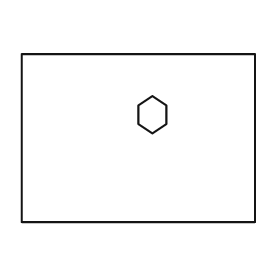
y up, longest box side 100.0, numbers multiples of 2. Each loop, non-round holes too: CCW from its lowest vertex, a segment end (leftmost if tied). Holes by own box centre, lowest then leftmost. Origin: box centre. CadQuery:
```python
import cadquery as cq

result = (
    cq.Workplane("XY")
    .moveTo(-50.0, -36.0)
    .lineTo(50.0, -36.0)
    .lineTo(50.0, 36.0)
    .lineTo(-50.0, 36.0)
    .close()
    .moveTo(6.0, 2.0)
    .lineTo(12.0, 6.0)
    .lineTo(12.0, 14.0)
    .lineTo(6.0, 18.0)
    .lineTo(0.0, 14.0)
    .lineTo(0.0, 6.0)
    .close()
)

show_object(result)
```